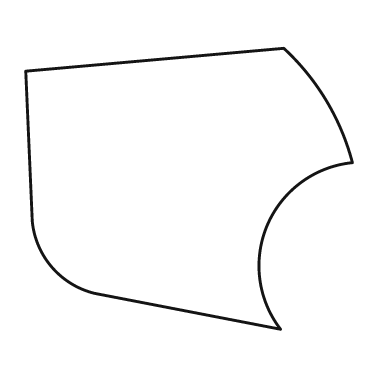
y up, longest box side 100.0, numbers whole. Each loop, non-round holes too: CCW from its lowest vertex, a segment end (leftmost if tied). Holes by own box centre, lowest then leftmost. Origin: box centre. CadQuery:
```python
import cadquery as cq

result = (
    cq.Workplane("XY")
    .moveTo(28.0, -43.0)
    .threePointArc((24.0, -11.0), (50.0, 8.0))
    .threePointArc((42.0, 27.0), (29.0, 43.0))
    .lineTo(-50.0, 36.0)
    .lineTo(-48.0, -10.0)
    .threePointArc((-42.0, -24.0), (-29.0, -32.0))
    .close()
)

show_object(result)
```